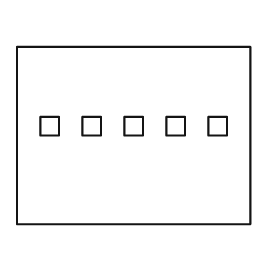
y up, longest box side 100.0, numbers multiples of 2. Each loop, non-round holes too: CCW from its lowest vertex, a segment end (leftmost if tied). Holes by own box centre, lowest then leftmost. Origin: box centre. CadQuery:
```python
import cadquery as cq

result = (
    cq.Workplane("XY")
    .moveTo(-50.0, -38.0)
    .lineTo(50.0, -38.0)
    .lineTo(50.0, 38.0)
    .lineTo(-50.0, 38.0)
    .close()
    .moveTo(-40.0, 0.0)
    .lineTo(-32.0, 0.0)
    .lineTo(-32.0, 8.0)
    .lineTo(-40.0, 8.0)
    .close()
    .moveTo(-22.0, 0.0)
    .lineTo(-14.0, 0.0)
    .lineTo(-14.0, 8.0)
    .lineTo(-22.0, 8.0)
    .close()
    .moveTo(-4.0, 0.0)
    .lineTo(4.0, 0.0)
    .lineTo(4.0, 8.0)
    .lineTo(-4.0, 8.0)
    .close()
    .moveTo(14.0, 0.0)
    .lineTo(22.0, 0.0)
    .lineTo(22.0, 8.0)
    .lineTo(14.0, 8.0)
    .close()
    .moveTo(32.0, 0.0)
    .lineTo(40.0, 0.0)
    .lineTo(40.0, 8.0)
    .lineTo(32.0, 8.0)
    .close()
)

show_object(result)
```